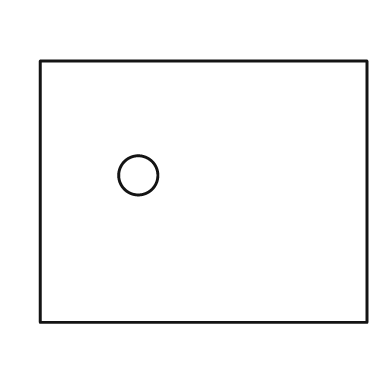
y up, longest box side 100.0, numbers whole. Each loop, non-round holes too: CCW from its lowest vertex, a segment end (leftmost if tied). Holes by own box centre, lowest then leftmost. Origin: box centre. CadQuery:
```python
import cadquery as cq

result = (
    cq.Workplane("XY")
    .moveTo(-50.0, -40.0)
    .lineTo(50.0, -40.0)
    .lineTo(50.0, 40.0)
    .lineTo(-50.0, 40.0)
    .close()
    .moveTo(-20.0, 5.0)
    .circle(6.0)
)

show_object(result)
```